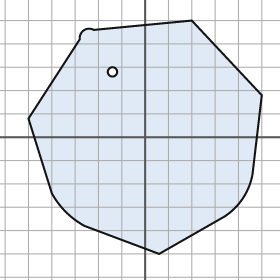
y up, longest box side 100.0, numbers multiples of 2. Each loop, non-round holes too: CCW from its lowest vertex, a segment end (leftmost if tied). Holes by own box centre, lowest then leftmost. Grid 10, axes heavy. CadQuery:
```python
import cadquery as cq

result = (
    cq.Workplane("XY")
    .moveTo(6.0, -50.0)
    .lineTo(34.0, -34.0)
    .threePointArc((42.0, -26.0), (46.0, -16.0))
    .lineTo(50.0, 18.0)
    .lineTo(20.0, 50.0)
    .lineTo(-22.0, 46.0)
    .threePointArc((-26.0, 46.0), (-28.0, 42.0))
    .lineTo(-50.0, 8.0)
    .lineTo(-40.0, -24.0)
    .threePointArc((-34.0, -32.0), (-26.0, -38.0))
    .close()
    .moveTo(-14.0, 28.0)
    .circle(2.0)
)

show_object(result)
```